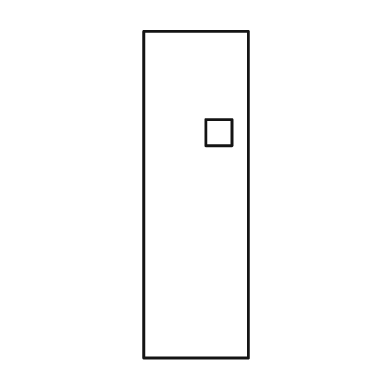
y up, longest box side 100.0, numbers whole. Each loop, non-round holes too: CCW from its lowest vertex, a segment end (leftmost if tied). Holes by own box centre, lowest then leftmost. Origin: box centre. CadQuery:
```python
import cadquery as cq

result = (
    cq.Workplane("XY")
    .moveTo(-16.0, -50.0)
    .lineTo(16.0, -50.0)
    .lineTo(16.0, 50.0)
    .lineTo(-16.0, 50.0)
    .close()
    .moveTo(3.0, 15.0)
    .lineTo(11.0, 15.0)
    .lineTo(11.0, 23.0)
    .lineTo(3.0, 23.0)
    .close()
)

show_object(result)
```